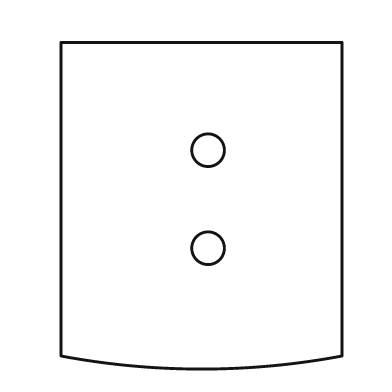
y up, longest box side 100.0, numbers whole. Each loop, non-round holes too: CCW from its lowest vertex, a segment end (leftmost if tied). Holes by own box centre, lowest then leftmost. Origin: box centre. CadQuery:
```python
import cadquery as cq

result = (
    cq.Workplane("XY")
    .moveTo(-43.0, -46.0)
    .threePointArc((0.0, -50.0), (43.0, -46.0))
    .lineTo(43.0, 50.0)
    .lineTo(-43.0, 50.0)
    .close()
    .moveTo(2.0, -13.0)
    .circle(5.0)
    .moveTo(2.0, 17.0)
    .circle(5.0)
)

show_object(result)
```